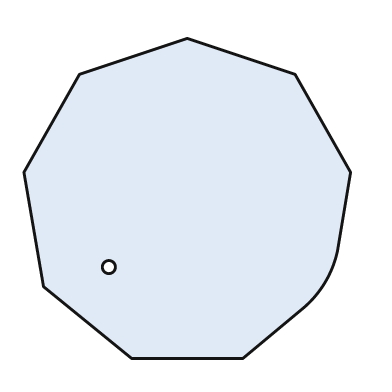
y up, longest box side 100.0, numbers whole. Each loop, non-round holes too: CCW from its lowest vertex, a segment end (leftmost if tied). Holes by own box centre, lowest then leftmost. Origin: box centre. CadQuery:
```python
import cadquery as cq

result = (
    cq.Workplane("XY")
    .moveTo(-17.0, -49.0)
    .lineTo(17.0, -49.0)
    .lineTo(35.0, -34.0)
    .threePointArc((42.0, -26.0), (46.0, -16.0))
    .lineTo(50.0, 8.0)
    .lineTo(33.0, 38.0)
    .lineTo(0.0, 49.0)
    .lineTo(-33.0, 38.0)
    .lineTo(-50.0, 8.0)
    .lineTo(-44.0, -27.0)
    .close()
    .moveTo(-24.0, -21.0)
    .circle(2.0)
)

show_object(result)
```